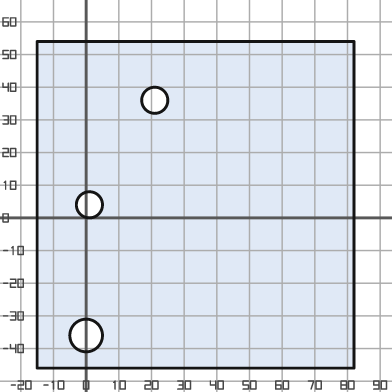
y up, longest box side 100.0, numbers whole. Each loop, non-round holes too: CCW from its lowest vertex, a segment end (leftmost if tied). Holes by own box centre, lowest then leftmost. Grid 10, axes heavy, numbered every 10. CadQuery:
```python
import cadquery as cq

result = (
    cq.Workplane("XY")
    .moveTo(-15.0, -46.0)
    .lineTo(82.0, -46.0)
    .lineTo(82.0, 54.0)
    .lineTo(-15.0, 54.0)
    .close()
    .moveTo(0.0, -36.0)
    .circle(5.0)
    .moveTo(1.0, 4.0)
    .circle(4.0)
    .moveTo(21.0, 36.0)
    .circle(4.0)
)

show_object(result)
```